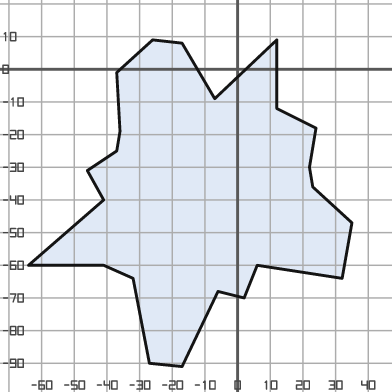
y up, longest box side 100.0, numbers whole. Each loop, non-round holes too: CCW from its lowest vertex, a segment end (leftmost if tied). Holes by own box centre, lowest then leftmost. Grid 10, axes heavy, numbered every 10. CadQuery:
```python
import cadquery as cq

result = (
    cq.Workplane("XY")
    .moveTo(-17.0, -91.0)
    .lineTo(-6.0, -68.0)
    .lineTo(2.0, -70.0)
    .lineTo(6.0, -60.0)
    .lineTo(32.0, -64.0)
    .lineTo(35.0, -47.0)
    .lineTo(23.0, -36.0)
    .lineTo(22.0, -30.0)
    .lineTo(24.0, -18.0)
    .lineTo(12.0, -12.0)
    .lineTo(12.0, 9.0)
    .lineTo(-7.0, -9.0)
    .lineTo(-17.0, 8.0)
    .lineTo(-26.0, 9.0)
    .lineTo(-37.0, -1.0)
    .lineTo(-36.0, -19.0)
    .lineTo(-37.0, -25.0)
    .lineTo(-46.0, -31.0)
    .lineTo(-41.0, -40.0)
    .lineTo(-64.0, -60.0)
    .lineTo(-41.0, -60.0)
    .lineTo(-32.0, -64.0)
    .lineTo(-27.0, -90.0)
    .close()
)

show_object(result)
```